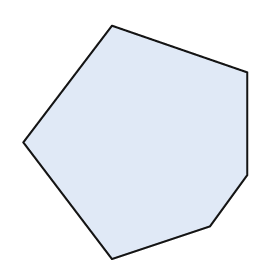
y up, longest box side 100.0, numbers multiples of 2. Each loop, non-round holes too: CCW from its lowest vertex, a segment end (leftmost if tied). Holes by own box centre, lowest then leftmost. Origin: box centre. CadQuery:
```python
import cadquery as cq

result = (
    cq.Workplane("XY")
    .moveTo(-10.0, -50.0)
    .lineTo(32.0, -36.0)
    .lineTo(48.0, -14.0)
    .lineTo(48.0, 30.0)
    .lineTo(-10.0, 50.0)
    .lineTo(-48.0, 0.0)
    .close()
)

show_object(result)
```